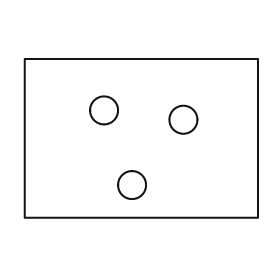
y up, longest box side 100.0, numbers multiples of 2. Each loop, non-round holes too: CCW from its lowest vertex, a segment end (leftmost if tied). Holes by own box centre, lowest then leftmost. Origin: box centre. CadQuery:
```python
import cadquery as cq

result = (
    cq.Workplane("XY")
    .moveTo(-50.0, -34.0)
    .lineTo(50.0, -34.0)
    .lineTo(50.0, 34.0)
    .lineTo(-50.0, 34.0)
    .close()
    .moveTo(-4.0, -20.0)
    .circle(6.0)
    .moveTo(18.0, 8.0)
    .circle(6.0)
    .moveTo(-16.0, 12.0)
    .circle(6.0)
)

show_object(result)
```